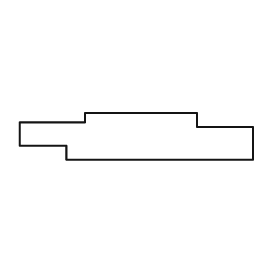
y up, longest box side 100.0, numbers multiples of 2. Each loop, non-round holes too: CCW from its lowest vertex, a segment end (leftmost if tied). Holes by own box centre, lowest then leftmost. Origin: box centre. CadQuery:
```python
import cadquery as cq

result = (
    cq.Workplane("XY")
    .moveTo(-30.0, -10.0)
    .lineTo(50.0, -10.0)
    .lineTo(50.0, 4.0)
    .lineTo(26.0, 4.0)
    .lineTo(26.0, 10.0)
    .lineTo(-22.0, 10.0)
    .lineTo(-22.0, 6.0)
    .lineTo(-50.0, 6.0)
    .lineTo(-50.0, -4.0)
    .lineTo(-30.0, -4.0)
    .close()
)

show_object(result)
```